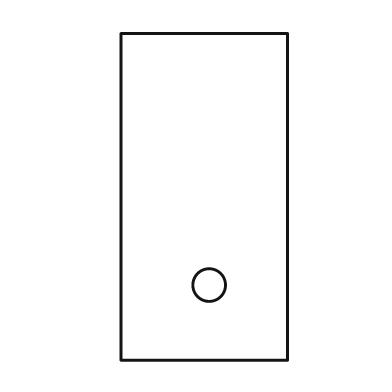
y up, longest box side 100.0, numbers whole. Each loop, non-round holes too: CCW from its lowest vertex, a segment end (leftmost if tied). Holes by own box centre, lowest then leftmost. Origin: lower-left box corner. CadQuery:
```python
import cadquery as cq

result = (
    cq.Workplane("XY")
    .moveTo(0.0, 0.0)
    .lineTo(51.0, 0.0)
    .lineTo(51.0, 100.0)
    .lineTo(0.0, 100.0)
    .close()
    .moveTo(27.0, 23.0)
    .circle(5.0)
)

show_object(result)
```